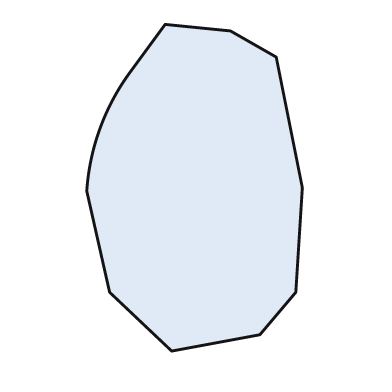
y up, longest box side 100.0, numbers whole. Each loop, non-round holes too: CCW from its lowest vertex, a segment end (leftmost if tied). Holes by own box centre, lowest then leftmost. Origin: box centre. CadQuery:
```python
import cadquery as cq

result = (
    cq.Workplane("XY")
    .moveTo(-7.0, -50.0)
    .lineTo(20.0, -45.0)
    .lineTo(31.0, -32.0)
    .lineTo(33.0, 0.0)
    .lineTo(25.0, 40.0)
    .lineTo(11.0, 48.0)
    .lineTo(-9.0, 50.0)
    .lineTo(-20.0, 35.0)
    .threePointArc((-29.0, 18.0), (-33.0, -1.0))
    .lineTo(-26.0, -32.0)
    .close()
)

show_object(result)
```